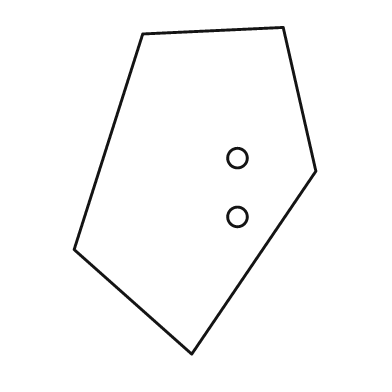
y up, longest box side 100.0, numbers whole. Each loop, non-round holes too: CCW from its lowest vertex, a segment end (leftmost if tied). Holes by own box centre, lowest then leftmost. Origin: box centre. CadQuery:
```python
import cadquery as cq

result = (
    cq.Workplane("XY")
    .moveTo(-1.0, -50.0)
    .lineTo(37.0, 6.0)
    .lineTo(27.0, 50.0)
    .lineTo(-16.0, 48.0)
    .lineTo(-37.0, -18.0)
    .close()
    .moveTo(13.0, -8.0)
    .circle(3.0)
    .moveTo(13.0, 10.0)
    .circle(3.0)
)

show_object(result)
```